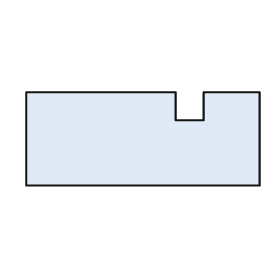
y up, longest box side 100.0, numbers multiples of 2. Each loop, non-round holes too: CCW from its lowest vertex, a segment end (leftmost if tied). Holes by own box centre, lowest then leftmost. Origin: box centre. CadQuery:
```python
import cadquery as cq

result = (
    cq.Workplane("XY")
    .moveTo(-50.0, -20.0)
    .lineTo(50.0, -20.0)
    .lineTo(50.0, 20.0)
    .lineTo(26.0, 20.0)
    .lineTo(26.0, 8.0)
    .lineTo(14.0, 8.0)
    .lineTo(14.0, 20.0)
    .lineTo(-50.0, 20.0)
    .close()
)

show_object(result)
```